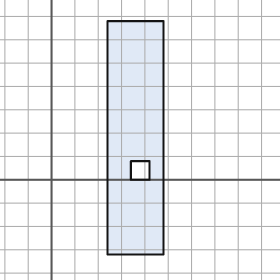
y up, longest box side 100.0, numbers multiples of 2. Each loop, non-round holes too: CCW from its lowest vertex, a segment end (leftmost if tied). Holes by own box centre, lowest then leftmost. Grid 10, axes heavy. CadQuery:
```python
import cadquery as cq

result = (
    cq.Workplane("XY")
    .moveTo(24.0, -32.0)
    .lineTo(48.0, -32.0)
    .lineTo(48.0, 68.0)
    .lineTo(24.0, 68.0)
    .close()
    .moveTo(34.0, 0.0)
    .lineTo(42.0, 0.0)
    .lineTo(42.0, 8.0)
    .lineTo(34.0, 8.0)
    .close()
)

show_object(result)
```